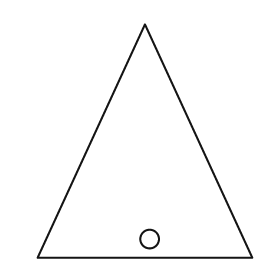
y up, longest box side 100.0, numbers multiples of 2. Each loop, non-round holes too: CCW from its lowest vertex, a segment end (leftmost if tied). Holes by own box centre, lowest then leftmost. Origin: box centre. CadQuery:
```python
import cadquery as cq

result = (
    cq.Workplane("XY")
    .moveTo(-46.0, -50.0)
    .lineTo(46.0, -50.0)
    .lineTo(0.0, 50.0)
    .close()
    .moveTo(2.0, -42.0)
    .circle(4.0)
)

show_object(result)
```